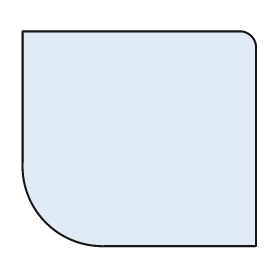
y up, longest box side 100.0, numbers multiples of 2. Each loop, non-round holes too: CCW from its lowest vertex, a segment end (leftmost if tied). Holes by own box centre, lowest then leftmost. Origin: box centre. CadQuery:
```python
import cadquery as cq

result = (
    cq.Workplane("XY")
    .moveTo(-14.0, -46.0)
    .lineTo(50.0, -46.0)
    .lineTo(50.0, 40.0)
    .threePointArc((48.0, 44.0), (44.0, 46.0))
    .lineTo(-50.0, 46.0)
    .lineTo(-50.0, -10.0)
    .threePointArc((-40.0, -36.0), (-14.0, -46.0))
    .close()
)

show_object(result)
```